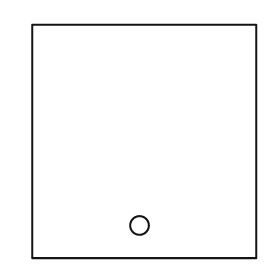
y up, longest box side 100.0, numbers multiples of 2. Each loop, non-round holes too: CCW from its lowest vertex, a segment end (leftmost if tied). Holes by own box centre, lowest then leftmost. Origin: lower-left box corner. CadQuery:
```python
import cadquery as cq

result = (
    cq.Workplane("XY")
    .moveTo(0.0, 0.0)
    .lineTo(96.0, 0.0)
    .lineTo(96.0, 100.0)
    .lineTo(0.0, 100.0)
    .close()
    .moveTo(46.0, 14.0)
    .circle(4.0)
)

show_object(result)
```